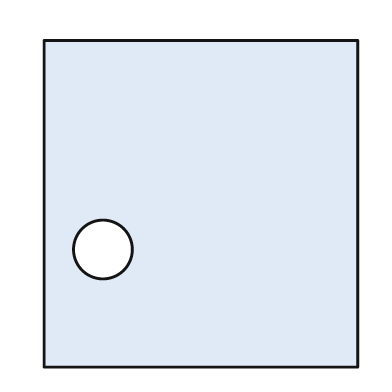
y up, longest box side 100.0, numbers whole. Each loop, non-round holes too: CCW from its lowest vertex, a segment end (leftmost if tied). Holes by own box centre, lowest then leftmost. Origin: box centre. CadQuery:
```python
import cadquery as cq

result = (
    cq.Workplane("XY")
    .moveTo(-48.0, -50.0)
    .lineTo(48.0, -50.0)
    .lineTo(48.0, 50.0)
    .lineTo(-48.0, 50.0)
    .close()
    .moveTo(-30.0, -14.0)
    .circle(9.0)
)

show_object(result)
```